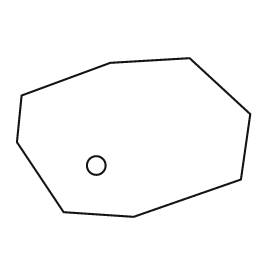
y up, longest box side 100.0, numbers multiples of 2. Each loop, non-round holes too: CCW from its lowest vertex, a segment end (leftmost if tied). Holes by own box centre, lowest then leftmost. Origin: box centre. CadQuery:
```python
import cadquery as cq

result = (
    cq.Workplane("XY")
    .moveTo(0.0, -34.0)
    .lineTo(46.0, -18.0)
    .lineTo(50.0, 10.0)
    .lineTo(24.0, 34.0)
    .lineTo(-10.0, 32.0)
    .lineTo(-48.0, 18.0)
    .lineTo(-50.0, -2.0)
    .lineTo(-30.0, -32.0)
    .close()
    .moveTo(-16.0, -12.0)
    .circle(4.0)
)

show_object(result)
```